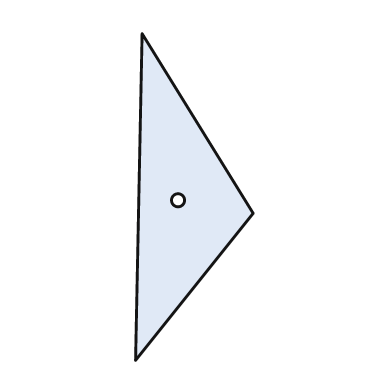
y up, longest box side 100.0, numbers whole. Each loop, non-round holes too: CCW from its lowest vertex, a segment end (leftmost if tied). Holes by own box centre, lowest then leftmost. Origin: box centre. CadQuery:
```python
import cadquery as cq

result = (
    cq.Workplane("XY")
    .moveTo(-18.0, -50.0)
    .lineTo(18.0, -5.0)
    .lineTo(-16.0, 50.0)
    .close()
    .moveTo(-5.0, -1.0)
    .circle(2.0)
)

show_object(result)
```